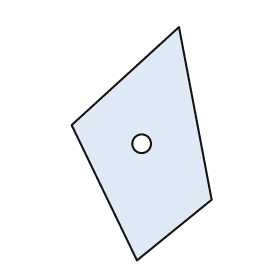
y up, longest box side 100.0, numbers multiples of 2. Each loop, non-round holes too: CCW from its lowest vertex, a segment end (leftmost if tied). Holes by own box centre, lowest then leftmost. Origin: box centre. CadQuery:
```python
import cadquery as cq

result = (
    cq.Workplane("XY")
    .moveTo(-2.0, -50.0)
    .lineTo(30.0, -24.0)
    .lineTo(16.0, 50.0)
    .lineTo(-30.0, 8.0)
    .close()
    .moveTo(0.0, 0.0)
    .circle(4.0)
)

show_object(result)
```